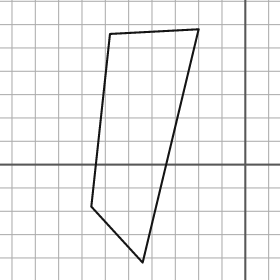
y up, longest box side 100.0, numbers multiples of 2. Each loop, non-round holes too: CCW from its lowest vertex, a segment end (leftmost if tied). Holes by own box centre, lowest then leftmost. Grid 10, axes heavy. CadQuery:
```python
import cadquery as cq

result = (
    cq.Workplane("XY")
    .moveTo(-44.0, -42.0)
    .lineTo(-20.0, 58.0)
    .lineTo(-58.0, 56.0)
    .lineTo(-66.0, -18.0)
    .close()
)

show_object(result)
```